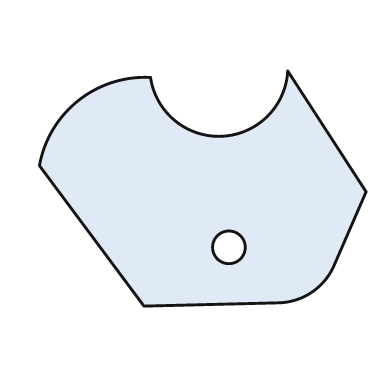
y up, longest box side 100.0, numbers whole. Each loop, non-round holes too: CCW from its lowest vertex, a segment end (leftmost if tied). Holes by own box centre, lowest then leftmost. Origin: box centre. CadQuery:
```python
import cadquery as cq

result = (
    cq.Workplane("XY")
    .moveTo(-18.0, -36.0)
    .lineTo(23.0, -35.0)
    .threePointArc((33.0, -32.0), (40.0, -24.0))
    .lineTo(50.0, -1.0)
    .lineTo(26.0, 36.0)
    .threePointArc((6.0, 16.0), (-16.0, 34.0))
    .threePointArc((-38.0, 27.0), (-50.0, 7.0))
    .close()
    .moveTo(8.0, -18.0)
    .circle(5.0)
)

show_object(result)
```